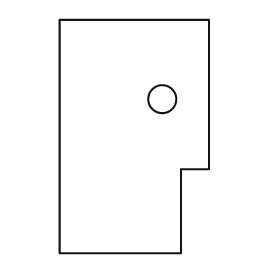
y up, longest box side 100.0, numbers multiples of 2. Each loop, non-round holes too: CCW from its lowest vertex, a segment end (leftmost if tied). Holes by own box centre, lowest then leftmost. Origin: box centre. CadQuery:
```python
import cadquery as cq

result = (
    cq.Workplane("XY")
    .moveTo(-32.0, -50.0)
    .lineTo(20.0, -50.0)
    .lineTo(20.0, -14.0)
    .lineTo(32.0, -14.0)
    .lineTo(32.0, 50.0)
    .lineTo(-32.0, 50.0)
    .close()
    .moveTo(12.0, 16.0)
    .circle(6.0)
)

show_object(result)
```